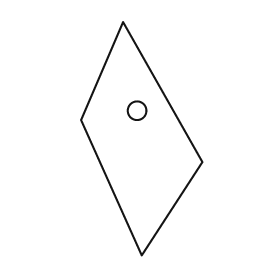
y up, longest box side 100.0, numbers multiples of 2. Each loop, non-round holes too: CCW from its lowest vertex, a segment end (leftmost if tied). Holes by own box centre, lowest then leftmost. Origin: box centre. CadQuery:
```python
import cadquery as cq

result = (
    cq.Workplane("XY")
    .moveTo(0.0, -50.0)
    .lineTo(26.0, -10.0)
    .lineTo(-8.0, 50.0)
    .lineTo(-26.0, 8.0)
    .close()
    .moveTo(-2.0, 12.0)
    .circle(4.0)
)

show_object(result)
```